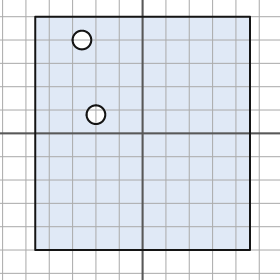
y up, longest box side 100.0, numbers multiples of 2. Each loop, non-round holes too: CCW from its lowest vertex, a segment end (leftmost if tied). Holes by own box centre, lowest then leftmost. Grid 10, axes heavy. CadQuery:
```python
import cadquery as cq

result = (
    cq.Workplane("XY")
    .moveTo(-46.0, -50.0)
    .lineTo(46.0, -50.0)
    .lineTo(46.0, 50.0)
    .lineTo(-46.0, 50.0)
    .close()
    .moveTo(-20.0, 8.0)
    .circle(4.0)
    .moveTo(-26.0, 40.0)
    .circle(4.0)
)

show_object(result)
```